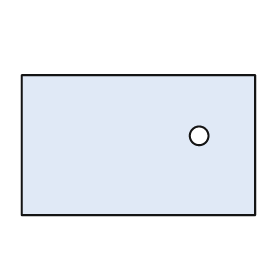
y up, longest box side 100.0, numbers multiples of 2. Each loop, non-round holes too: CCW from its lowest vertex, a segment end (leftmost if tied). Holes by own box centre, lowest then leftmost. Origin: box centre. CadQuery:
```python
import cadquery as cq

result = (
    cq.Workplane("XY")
    .moveTo(-50.0, -30.0)
    .lineTo(50.0, -30.0)
    .lineTo(50.0, 30.0)
    .lineTo(-50.0, 30.0)
    .close()
    .moveTo(26.0, 4.0)
    .circle(4.0)
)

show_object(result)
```